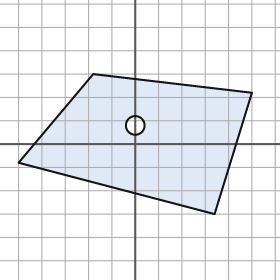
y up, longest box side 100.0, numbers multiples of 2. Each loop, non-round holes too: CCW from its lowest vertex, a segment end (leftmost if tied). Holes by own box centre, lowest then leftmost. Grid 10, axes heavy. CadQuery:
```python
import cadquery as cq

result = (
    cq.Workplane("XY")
    .moveTo(34.0, -30.0)
    .lineTo(50.0, 22.0)
    .lineTo(-18.0, 30.0)
    .lineTo(-50.0, -8.0)
    .close()
    .moveTo(0.0, 8.0)
    .circle(4.0)
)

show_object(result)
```